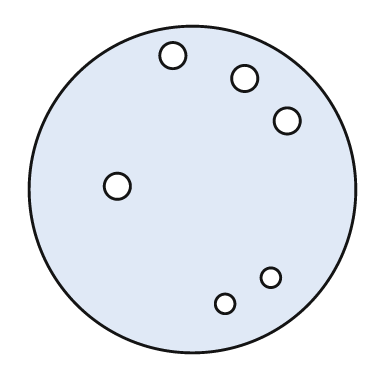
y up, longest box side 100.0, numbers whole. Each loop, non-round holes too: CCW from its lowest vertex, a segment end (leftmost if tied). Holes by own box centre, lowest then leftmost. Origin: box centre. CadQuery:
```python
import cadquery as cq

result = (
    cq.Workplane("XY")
    .moveTo(0.0, 0.0)
    .circle(50.0)
    .moveTo(10.0, -35.0)
    .circle(3.0)
    .moveTo(24.0, -27.0)
    .circle(3.0)
    .moveTo(-23.0, 1.0)
    .circle(4.0)
    .moveTo(29.0, 21.0)
    .circle(4.0)
    .moveTo(16.0, 34.0)
    .circle(4.0)
    .moveTo(-6.0, 41.0)
    .circle(4.0)
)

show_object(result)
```